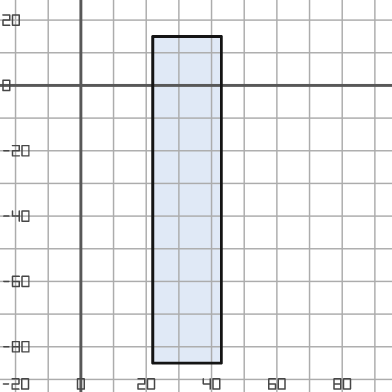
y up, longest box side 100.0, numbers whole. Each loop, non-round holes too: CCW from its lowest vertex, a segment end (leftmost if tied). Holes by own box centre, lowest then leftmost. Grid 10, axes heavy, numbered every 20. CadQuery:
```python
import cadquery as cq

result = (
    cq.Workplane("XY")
    .moveTo(22.0, -85.0)
    .lineTo(43.0, -85.0)
    .lineTo(43.0, 15.0)
    .lineTo(22.0, 15.0)
    .close()
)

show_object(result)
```